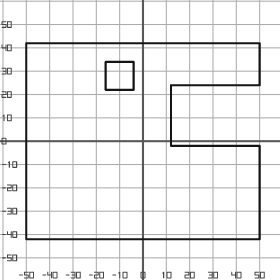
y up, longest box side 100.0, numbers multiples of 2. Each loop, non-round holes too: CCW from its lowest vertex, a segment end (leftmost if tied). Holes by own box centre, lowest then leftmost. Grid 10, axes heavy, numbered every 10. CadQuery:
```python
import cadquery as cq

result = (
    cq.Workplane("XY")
    .moveTo(-50.0, -42.0)
    .lineTo(50.0, -42.0)
    .lineTo(50.0, -2.0)
    .lineTo(12.0, -2.0)
    .lineTo(12.0, 24.0)
    .lineTo(50.0, 24.0)
    .lineTo(50.0, 42.0)
    .lineTo(-50.0, 42.0)
    .close()
    .moveTo(-16.0, 22.0)
    .lineTo(-4.0, 22.0)
    .lineTo(-4.0, 34.0)
    .lineTo(-16.0, 34.0)
    .close()
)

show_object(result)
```